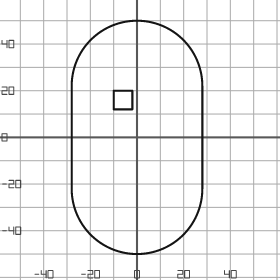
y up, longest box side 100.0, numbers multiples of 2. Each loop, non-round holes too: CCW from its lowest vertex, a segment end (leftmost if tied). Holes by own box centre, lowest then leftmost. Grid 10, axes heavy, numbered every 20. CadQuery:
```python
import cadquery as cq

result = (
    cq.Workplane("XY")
    .moveTo(-28.0, -22.0)
    .threePointArc((0.0, -50.0), (28.0, -22.0))
    .lineTo(28.0, 22.0)
    .threePointArc((0.0, 50.0), (-28.0, 22.0))
    .close()
    .moveTo(-10.0, 12.0)
    .lineTo(-2.0, 12.0)
    .lineTo(-2.0, 20.0)
    .lineTo(-10.0, 20.0)
    .close()
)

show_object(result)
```